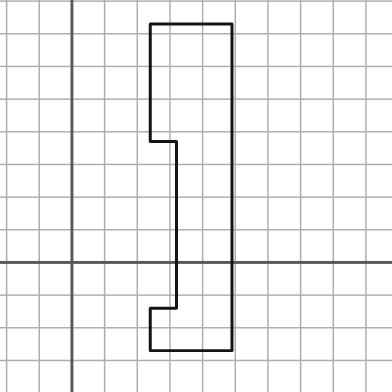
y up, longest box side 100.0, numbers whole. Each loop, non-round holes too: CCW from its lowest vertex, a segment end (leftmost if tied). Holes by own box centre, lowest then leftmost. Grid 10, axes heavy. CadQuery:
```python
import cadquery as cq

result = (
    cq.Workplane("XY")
    .moveTo(24.0, -27.0)
    .lineTo(49.0, -27.0)
    .lineTo(49.0, 73.0)
    .lineTo(24.0, 73.0)
    .lineTo(24.0, 37.0)
    .lineTo(32.0, 37.0)
    .lineTo(32.0, -14.0)
    .lineTo(24.0, -14.0)
    .close()
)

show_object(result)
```